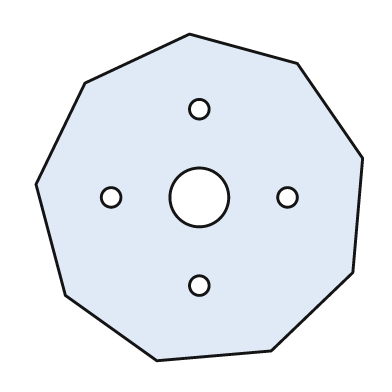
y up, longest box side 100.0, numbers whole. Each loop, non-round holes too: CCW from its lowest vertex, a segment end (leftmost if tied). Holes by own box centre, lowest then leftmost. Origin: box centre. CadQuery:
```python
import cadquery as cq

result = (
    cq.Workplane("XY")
    .moveTo(-13.0, -50.0)
    .lineTo(22.0, -47.0)
    .lineTo(47.0, -23.0)
    .lineTo(50.0, 12.0)
    .lineTo(30.0, 41.0)
    .lineTo(-3.0, 50.0)
    .lineTo(-35.0, 35.0)
    .lineTo(-50.0, 4.0)
    .lineTo(-41.0, -30.0)
    .close()
    .moveTo(0.0, -27.0)
    .circle(3.0)
    .moveTo(-27.0, 0.0)
    .circle(3.0)
    .moveTo(0.0, 0.0)
    .circle(9.0)
    .moveTo(27.0, 0.0)
    .circle(3.0)
    .moveTo(0.0, 27.0)
    .circle(3.0)
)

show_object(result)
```